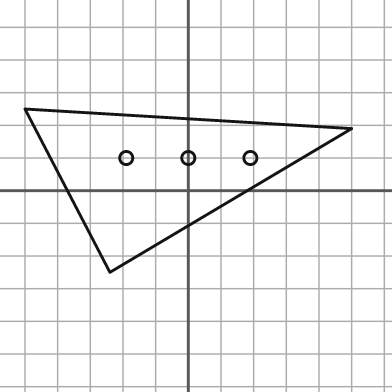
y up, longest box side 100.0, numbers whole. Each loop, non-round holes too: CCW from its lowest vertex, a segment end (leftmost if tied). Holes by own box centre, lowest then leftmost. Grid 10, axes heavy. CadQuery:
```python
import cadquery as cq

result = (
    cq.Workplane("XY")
    .moveTo(-24.0, -25.0)
    .lineTo(50.0, 19.0)
    .lineTo(-50.0, 25.0)
    .close()
    .moveTo(-19.0, 10.0)
    .circle(2.0)
    .moveTo(0.0, 10.0)
    .circle(2.0)
    .moveTo(19.0, 10.0)
    .circle(2.0)
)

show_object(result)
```